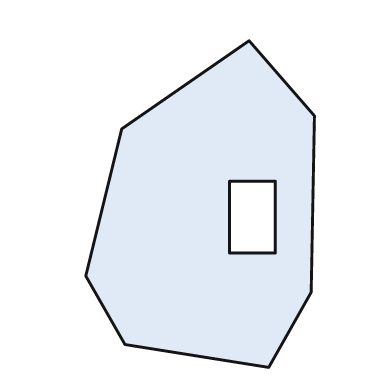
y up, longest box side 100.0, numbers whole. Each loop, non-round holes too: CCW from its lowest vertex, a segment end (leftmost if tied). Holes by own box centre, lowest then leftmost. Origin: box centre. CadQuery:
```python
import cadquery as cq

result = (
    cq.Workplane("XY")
    .moveTo(21.0, -50.0)
    .lineTo(34.0, -27.0)
    .lineTo(35.0, 27.0)
    .lineTo(15.0, 50.0)
    .lineTo(-24.0, 23.0)
    .lineTo(-35.0, -22.0)
    .lineTo(-23.0, -43.0)
    .close()
    .moveTo(9.0, -15.0)
    .lineTo(23.0, -15.0)
    .lineTo(23.0, 7.0)
    .lineTo(9.0, 7.0)
    .close()
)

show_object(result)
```